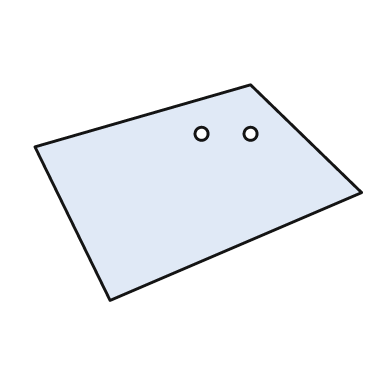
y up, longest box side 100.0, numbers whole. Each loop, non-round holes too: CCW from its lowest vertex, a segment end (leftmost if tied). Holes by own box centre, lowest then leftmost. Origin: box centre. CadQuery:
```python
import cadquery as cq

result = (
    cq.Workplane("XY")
    .moveTo(-27.0, -33.0)
    .lineTo(50.0, 0.0)
    .lineTo(16.0, 33.0)
    .lineTo(-50.0, 14.0)
    .close()
    .moveTo(1.0, 18.0)
    .circle(2.0)
    .moveTo(16.0, 18.0)
    .circle(2.0)
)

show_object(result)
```